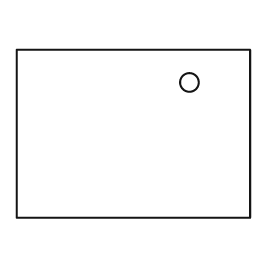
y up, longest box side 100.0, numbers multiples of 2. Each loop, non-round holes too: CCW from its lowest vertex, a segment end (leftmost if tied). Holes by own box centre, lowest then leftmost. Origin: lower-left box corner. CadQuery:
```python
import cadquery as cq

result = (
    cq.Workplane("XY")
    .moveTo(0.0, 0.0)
    .lineTo(100.0, 0.0)
    .lineTo(100.0, 72.0)
    .lineTo(0.0, 72.0)
    .close()
    .moveTo(74.0, 58.0)
    .circle(4.0)
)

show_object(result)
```